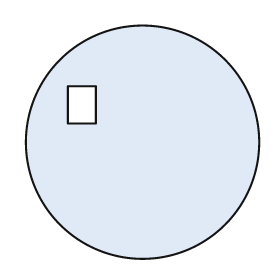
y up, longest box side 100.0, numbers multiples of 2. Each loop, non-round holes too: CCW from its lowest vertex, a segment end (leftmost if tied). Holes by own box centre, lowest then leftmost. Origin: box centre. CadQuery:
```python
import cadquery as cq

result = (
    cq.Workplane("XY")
    .moveTo(0.0, 0.0)
    .circle(50.0)
    .moveTo(-32.0, 8.0)
    .lineTo(-20.0, 8.0)
    .lineTo(-20.0, 24.0)
    .lineTo(-32.0, 24.0)
    .close()
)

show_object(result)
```